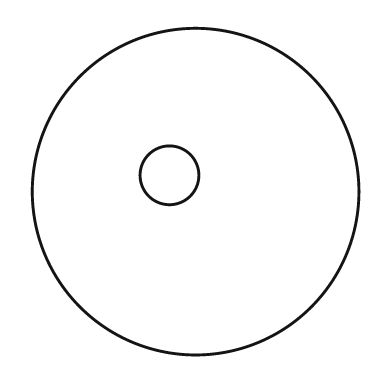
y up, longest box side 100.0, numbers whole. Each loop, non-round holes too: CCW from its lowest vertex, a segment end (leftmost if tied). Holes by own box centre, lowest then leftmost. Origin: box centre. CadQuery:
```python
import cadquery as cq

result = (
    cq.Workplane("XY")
    .moveTo(0.0, 0.0)
    .circle(50.0)
    .moveTo(-8.0, 5.0)
    .circle(9.0)
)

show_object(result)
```